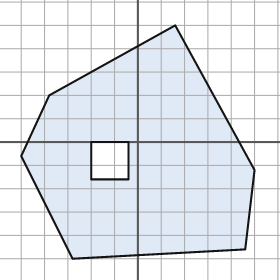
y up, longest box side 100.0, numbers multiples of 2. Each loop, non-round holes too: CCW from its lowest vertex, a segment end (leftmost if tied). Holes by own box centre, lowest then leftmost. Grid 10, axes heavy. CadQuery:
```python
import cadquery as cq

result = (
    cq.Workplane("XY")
    .moveTo(-28.0, -50.0)
    .lineTo(46.0, -46.0)
    .lineTo(50.0, -12.0)
    .lineTo(16.0, 50.0)
    .lineTo(-38.0, 20.0)
    .lineTo(-50.0, -6.0)
    .close()
    .moveTo(-20.0, -16.0)
    .lineTo(-4.0, -16.0)
    .lineTo(-4.0, 0.0)
    .lineTo(-20.0, 0.0)
    .close()
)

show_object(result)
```